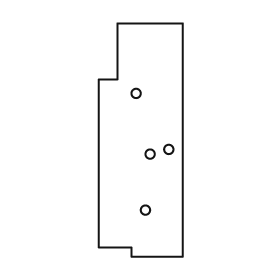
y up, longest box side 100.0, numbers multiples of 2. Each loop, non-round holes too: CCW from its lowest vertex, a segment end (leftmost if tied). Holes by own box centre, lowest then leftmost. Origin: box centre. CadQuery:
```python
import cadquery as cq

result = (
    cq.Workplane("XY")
    .moveTo(-4.0, -50.0)
    .lineTo(18.0, -50.0)
    .lineTo(18.0, 50.0)
    .lineTo(-10.0, 50.0)
    .lineTo(-10.0, 26.0)
    .lineTo(-18.0, 26.0)
    .lineTo(-18.0, -46.0)
    .lineTo(-4.0, -46.0)
    .close()
    .moveTo(2.0, -30.0)
    .circle(2.0)
    .moveTo(4.0, -6.0)
    .circle(2.0)
    .moveTo(12.0, -4.0)
    .circle(2.0)
    .moveTo(-2.0, 20.0)
    .circle(2.0)
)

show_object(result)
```